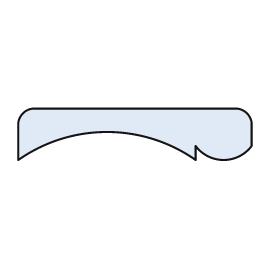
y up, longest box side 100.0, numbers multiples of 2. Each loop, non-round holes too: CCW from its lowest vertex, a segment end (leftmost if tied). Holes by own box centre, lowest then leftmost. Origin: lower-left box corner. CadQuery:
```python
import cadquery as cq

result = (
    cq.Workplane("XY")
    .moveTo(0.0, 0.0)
    .threePointArc((38.0, 12.0), (76.0, 0.0))
    .lineTo(76.0, 6.0)
    .threePointArc((88.0, 0.0), (100.0, 6.0))
    .lineTo(100.0, 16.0)
    .threePointArc((98.0, 20.0), (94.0, 22.0))
    .lineTo(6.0, 22.0)
    .threePointArc((2.0, 20.0), (0.0, 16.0))
    .close()
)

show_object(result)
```